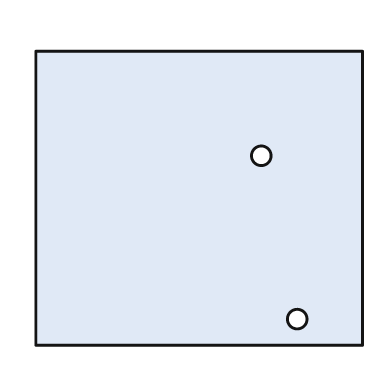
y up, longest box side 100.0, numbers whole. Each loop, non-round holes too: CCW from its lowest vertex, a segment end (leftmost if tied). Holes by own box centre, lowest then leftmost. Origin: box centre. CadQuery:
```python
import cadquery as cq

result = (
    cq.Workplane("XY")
    .moveTo(-50.0, -45.0)
    .lineTo(50.0, -45.0)
    .lineTo(50.0, 45.0)
    .lineTo(-50.0, 45.0)
    .close()
    .moveTo(30.0, -37.0)
    .circle(3.0)
    .moveTo(19.0, 13.0)
    .circle(3.0)
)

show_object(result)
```